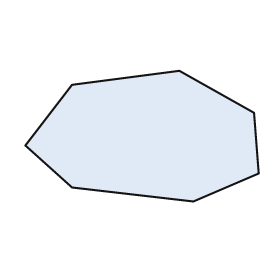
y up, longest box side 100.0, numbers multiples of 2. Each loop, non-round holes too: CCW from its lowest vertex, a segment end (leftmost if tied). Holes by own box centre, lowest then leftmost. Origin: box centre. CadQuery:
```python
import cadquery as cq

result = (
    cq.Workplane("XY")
    .moveTo(22.0, -28.0)
    .lineTo(50.0, -16.0)
    .lineTo(48.0, 10.0)
    .lineTo(16.0, 28.0)
    .lineTo(-30.0, 22.0)
    .lineTo(-50.0, -4.0)
    .lineTo(-30.0, -22.0)
    .close()
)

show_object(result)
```